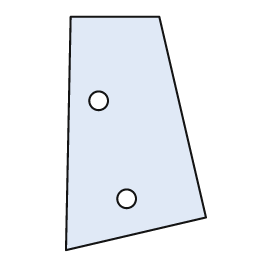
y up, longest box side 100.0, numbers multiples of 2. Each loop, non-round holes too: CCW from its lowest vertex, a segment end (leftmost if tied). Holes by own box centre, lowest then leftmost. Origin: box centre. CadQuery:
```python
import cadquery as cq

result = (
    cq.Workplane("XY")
    .moveTo(-30.0, -50.0)
    .lineTo(30.0, -36.0)
    .lineTo(10.0, 50.0)
    .lineTo(-28.0, 50.0)
    .close()
    .moveTo(-4.0, -28.0)
    .circle(4.0)
    .moveTo(-16.0, 14.0)
    .circle(4.0)
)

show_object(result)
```